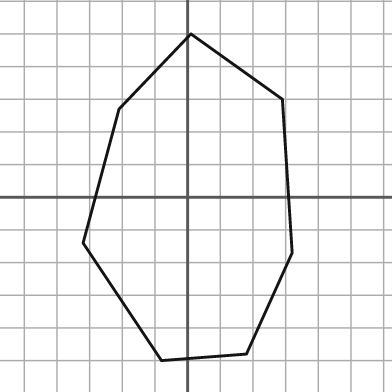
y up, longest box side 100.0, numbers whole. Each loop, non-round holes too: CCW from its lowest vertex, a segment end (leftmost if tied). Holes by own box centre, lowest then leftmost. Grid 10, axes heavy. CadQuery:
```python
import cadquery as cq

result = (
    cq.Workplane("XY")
    .moveTo(-8.0, -50.0)
    .lineTo(18.0, -48.0)
    .lineTo(32.0, -17.0)
    .lineTo(29.0, 30.0)
    .lineTo(1.0, 50.0)
    .lineTo(-21.0, 27.0)
    .lineTo(-32.0, -14.0)
    .close()
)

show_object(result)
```